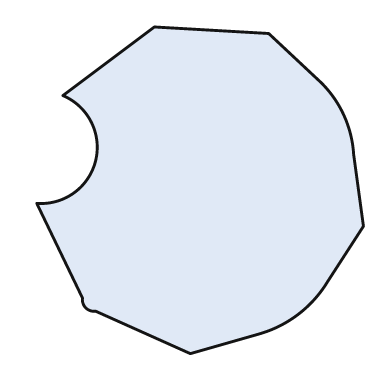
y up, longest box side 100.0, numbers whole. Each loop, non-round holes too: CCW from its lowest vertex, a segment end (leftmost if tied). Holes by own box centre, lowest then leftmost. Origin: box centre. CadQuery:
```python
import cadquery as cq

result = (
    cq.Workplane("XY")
    .moveTo(-3.0, -50.0)
    .lineTo(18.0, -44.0)
    .threePointArc((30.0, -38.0), (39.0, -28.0))
    .lineTo(50.0, -11.0)
    .lineTo(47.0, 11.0)
    .threePointArc((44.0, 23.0), (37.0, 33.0))
    .lineTo(21.0, 48.0)
    .lineTo(-14.0, 50.0)
    .lineTo(-42.0, 29.0)
    .threePointArc((-32.0, 9.0), (-50.0, -4.0))
    .lineTo(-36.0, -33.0)
    .threePointArc((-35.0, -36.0), (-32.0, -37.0))
    .close()
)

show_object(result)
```